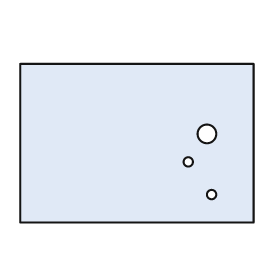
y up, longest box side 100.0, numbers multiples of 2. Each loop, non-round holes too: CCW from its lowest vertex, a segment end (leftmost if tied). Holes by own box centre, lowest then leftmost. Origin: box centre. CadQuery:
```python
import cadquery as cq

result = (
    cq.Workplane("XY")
    .moveTo(-50.0, -34.0)
    .lineTo(50.0, -34.0)
    .lineTo(50.0, 34.0)
    .lineTo(-50.0, 34.0)
    .close()
    .moveTo(32.0, -22.0)
    .circle(2.0)
    .moveTo(22.0, -8.0)
    .circle(2.0)
    .moveTo(30.0, 4.0)
    .circle(4.0)
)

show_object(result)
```